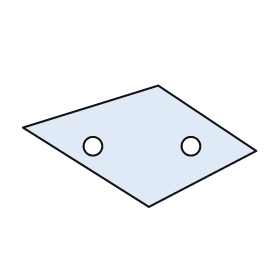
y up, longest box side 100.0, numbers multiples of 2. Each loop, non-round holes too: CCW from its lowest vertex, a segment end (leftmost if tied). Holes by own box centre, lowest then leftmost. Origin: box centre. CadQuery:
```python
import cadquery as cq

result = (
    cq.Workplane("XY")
    .moveTo(4.0, -26.0)
    .lineTo(50.0, -2.0)
    .lineTo(8.0, 26.0)
    .lineTo(-50.0, 8.0)
    .close()
    .moveTo(-20.0, 0.0)
    .circle(4.0)
    .moveTo(22.0, 0.0)
    .circle(4.0)
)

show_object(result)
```